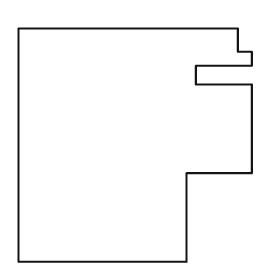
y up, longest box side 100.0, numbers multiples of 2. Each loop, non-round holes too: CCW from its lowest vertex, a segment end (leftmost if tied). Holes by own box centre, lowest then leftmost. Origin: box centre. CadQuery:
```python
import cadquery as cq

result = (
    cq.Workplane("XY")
    .moveTo(-50.0, -50.0)
    .lineTo(22.0, -50.0)
    .lineTo(22.0, -12.0)
    .lineTo(50.0, -12.0)
    .lineTo(50.0, 26.0)
    .lineTo(26.0, 26.0)
    .lineTo(26.0, 34.0)
    .lineTo(50.0, 34.0)
    .lineTo(50.0, 40.0)
    .lineTo(44.0, 40.0)
    .lineTo(44.0, 50.0)
    .lineTo(-50.0, 50.0)
    .close()
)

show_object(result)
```